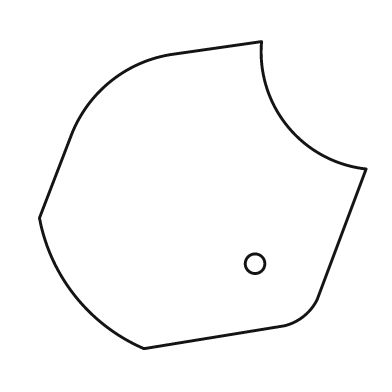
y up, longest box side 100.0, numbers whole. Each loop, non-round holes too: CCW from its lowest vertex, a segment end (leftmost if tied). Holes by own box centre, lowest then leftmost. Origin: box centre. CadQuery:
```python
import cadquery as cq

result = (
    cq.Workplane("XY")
    .moveTo(-18.0, -47.0)
    .lineTo(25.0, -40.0)
    .threePointArc((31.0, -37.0), (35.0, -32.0))
    .lineTo(50.0, 8.0)
    .threePointArc((26.0, 21.0), (18.0, 47.0))
    .lineTo(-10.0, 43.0)
    .threePointArc((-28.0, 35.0), (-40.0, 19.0))
    .lineTo(-50.0, -7.0)
    .threePointArc((-39.0, -31.0), (-18.0, -47.0))
    .close()
    .moveTo(16.0, -21.0)
    .circle(3.0)
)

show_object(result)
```